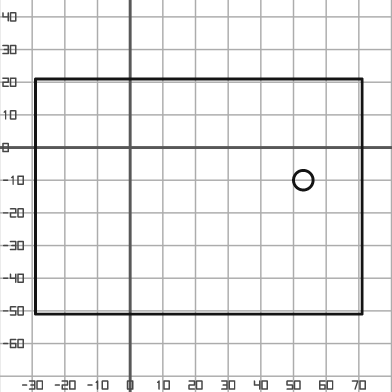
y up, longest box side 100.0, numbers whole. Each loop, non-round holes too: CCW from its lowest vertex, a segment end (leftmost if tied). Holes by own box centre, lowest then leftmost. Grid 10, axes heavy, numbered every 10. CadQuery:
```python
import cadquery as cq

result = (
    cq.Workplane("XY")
    .moveTo(-29.0, -51.0)
    .lineTo(71.0, -51.0)
    .lineTo(71.0, 21.0)
    .lineTo(-29.0, 21.0)
    .close()
    .moveTo(53.0, -10.0)
    .circle(3.0)
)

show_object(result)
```